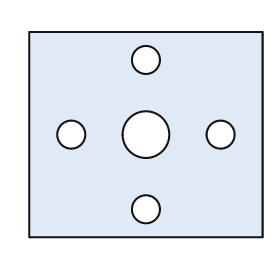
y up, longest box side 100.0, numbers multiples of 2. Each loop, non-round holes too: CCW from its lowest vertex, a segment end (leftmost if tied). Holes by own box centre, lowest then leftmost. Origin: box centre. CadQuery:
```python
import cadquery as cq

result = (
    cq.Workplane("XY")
    .moveTo(-50.0, -44.0)
    .lineTo(50.0, -44.0)
    .lineTo(50.0, 44.0)
    .lineTo(-50.0, 44.0)
    .close()
    .moveTo(0.0, -32.0)
    .circle(6.0)
    .moveTo(-32.0, 0.0)
    .circle(6.0)
    .moveTo(0.0, 0.0)
    .circle(10.0)
    .moveTo(32.0, 0.0)
    .circle(6.0)
    .moveTo(0.0, 32.0)
    .circle(6.0)
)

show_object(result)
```